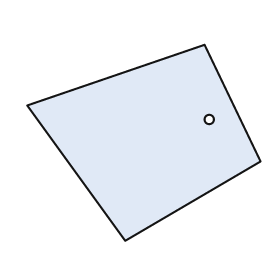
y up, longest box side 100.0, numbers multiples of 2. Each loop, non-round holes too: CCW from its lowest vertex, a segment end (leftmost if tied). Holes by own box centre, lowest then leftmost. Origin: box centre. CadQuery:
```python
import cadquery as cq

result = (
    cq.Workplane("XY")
    .moveTo(-8.0, -42.0)
    .lineTo(50.0, -8.0)
    .lineTo(26.0, 42.0)
    .lineTo(-50.0, 16.0)
    .close()
    .moveTo(28.0, 10.0)
    .circle(2.0)
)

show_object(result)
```